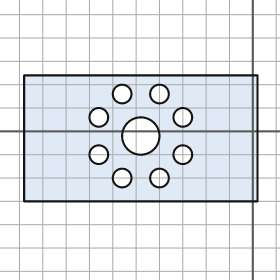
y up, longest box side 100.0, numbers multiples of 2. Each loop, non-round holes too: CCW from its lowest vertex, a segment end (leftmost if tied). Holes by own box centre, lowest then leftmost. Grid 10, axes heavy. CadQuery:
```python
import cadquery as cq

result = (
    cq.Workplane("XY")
    .moveTo(-98.0, -30.0)
    .lineTo(2.0, -30.0)
    .lineTo(2.0, 24.0)
    .lineTo(-98.0, 24.0)
    .close()
    .moveTo(-56.0, -20.0)
    .circle(4.0)
    .moveTo(-40.0, -20.0)
    .circle(4.0)
    .moveTo(-66.0, -10.0)
    .circle(4.0)
    .moveTo(-30.0, -10.0)
    .circle(4.0)
    .moveTo(-48.0, -2.0)
    .circle(8.0)
    .moveTo(-66.0, 6.0)
    .circle(4.0)
    .moveTo(-30.0, 6.0)
    .circle(4.0)
    .moveTo(-56.0, 16.0)
    .circle(4.0)
    .moveTo(-40.0, 16.0)
    .circle(4.0)
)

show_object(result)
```